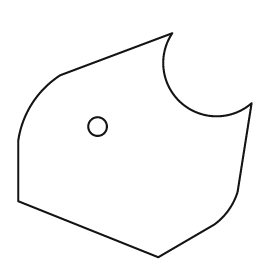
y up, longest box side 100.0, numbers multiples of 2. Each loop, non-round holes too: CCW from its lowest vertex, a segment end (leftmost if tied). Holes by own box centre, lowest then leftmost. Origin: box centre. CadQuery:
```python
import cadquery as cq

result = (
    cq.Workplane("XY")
    .moveTo(10.0, -48.0)
    .lineTo(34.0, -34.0)
    .threePointArc((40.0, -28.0), (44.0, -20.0))
    .lineTo(50.0, 18.0)
    .threePointArc((20.0, 18.0), (16.0, 48.0))
    .lineTo(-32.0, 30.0)
    .threePointArc((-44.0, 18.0), (-50.0, 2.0))
    .lineTo(-50.0, -24.0)
    .close()
    .moveTo(-16.0, 8.0)
    .circle(4.0)
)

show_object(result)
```